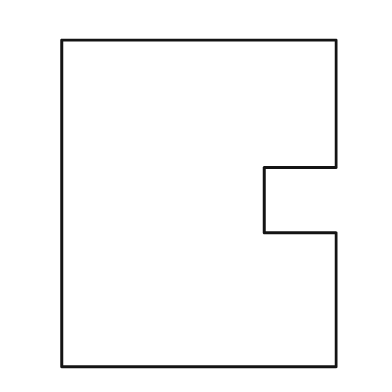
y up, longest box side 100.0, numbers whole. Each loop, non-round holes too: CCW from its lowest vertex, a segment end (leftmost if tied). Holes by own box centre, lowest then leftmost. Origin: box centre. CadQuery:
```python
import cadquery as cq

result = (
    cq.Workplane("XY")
    .moveTo(-42.0, -50.0)
    .lineTo(42.0, -50.0)
    .lineTo(42.0, -9.0)
    .lineTo(20.0, -9.0)
    .lineTo(20.0, 11.0)
    .lineTo(42.0, 11.0)
    .lineTo(42.0, 50.0)
    .lineTo(-42.0, 50.0)
    .close()
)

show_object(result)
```